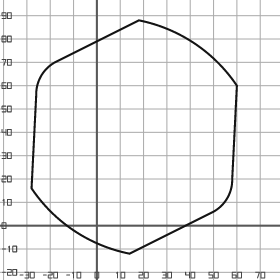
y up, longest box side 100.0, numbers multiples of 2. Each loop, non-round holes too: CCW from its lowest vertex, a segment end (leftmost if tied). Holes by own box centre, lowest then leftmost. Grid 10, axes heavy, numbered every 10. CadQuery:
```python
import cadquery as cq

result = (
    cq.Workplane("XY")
    .moveTo(14.0, -12.0)
    .lineTo(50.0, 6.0)
    .threePointArc((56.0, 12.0), (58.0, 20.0))
    .lineTo(60.0, 60.0)
    .threePointArc((42.0, 78.0), (18.0, 88.0))
    .lineTo(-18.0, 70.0)
    .threePointArc((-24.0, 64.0), (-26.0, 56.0))
    .lineTo(-28.0, 16.0)
    .threePointArc((-10.0, -2.0), (14.0, -12.0))
    .close()
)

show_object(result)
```